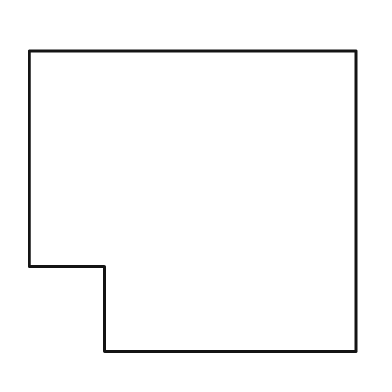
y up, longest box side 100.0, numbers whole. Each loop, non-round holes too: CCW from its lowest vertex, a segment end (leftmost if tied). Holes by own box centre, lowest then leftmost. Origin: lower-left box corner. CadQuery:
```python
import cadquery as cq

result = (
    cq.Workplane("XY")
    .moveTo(23.0, 0.0)
    .lineTo(100.0, 0.0)
    .lineTo(100.0, 92.0)
    .lineTo(0.0, 92.0)
    .lineTo(0.0, 26.0)
    .lineTo(23.0, 26.0)
    .close()
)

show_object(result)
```